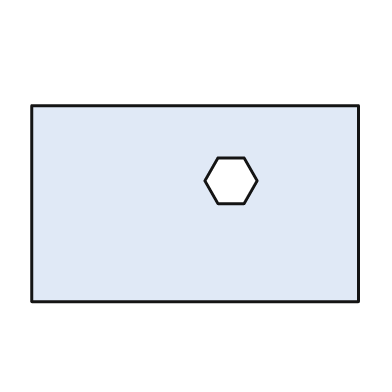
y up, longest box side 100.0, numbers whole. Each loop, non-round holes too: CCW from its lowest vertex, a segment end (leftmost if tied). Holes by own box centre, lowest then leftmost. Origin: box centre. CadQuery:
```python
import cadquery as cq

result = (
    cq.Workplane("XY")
    .moveTo(-50.0, -30.0)
    .lineTo(50.0, -30.0)
    .lineTo(50.0, 30.0)
    .lineTo(-50.0, 30.0)
    .close()
    .moveTo(7.0, 0.0)
    .lineTo(15.0, 0.0)
    .lineTo(19.0, 7.0)
    .lineTo(15.0, 14.0)
    .lineTo(7.0, 14.0)
    .lineTo(3.0, 7.0)
    .close()
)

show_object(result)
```